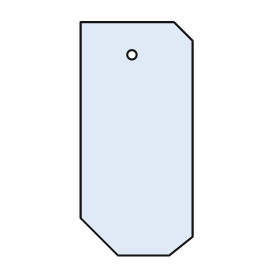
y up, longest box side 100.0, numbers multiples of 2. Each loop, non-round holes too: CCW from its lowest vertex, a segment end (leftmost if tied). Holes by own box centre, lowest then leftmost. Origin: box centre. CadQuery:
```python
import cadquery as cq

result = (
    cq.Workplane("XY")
    .moveTo(-8.0, -50.0)
    .lineTo(14.0, -50.0)
    .lineTo(24.0, -42.0)
    .lineTo(24.0, 42.0)
    .lineTo(16.0, 50.0)
    .lineTo(-24.0, 50.0)
    .lineTo(-24.0, -34.0)
    .close()
    .moveTo(-2.0, 36.0)
    .circle(2.0)
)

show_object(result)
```